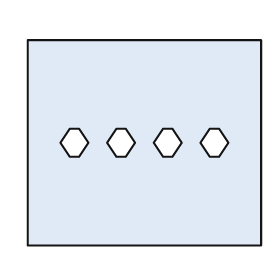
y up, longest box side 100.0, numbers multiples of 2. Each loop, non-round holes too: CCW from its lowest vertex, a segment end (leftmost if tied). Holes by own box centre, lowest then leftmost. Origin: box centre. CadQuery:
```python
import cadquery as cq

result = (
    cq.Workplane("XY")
    .moveTo(-50.0, -44.0)
    .lineTo(50.0, -44.0)
    .lineTo(50.0, 44.0)
    .lineTo(-50.0, 44.0)
    .close()
    .moveTo(-32.0, -6.0)
    .lineTo(-28.0, -6.0)
    .lineTo(-24.0, 0.0)
    .lineTo(-28.0, 6.0)
    .lineTo(-32.0, 6.0)
    .lineTo(-36.0, 0.0)
    .close()
    .moveTo(-12.0, -6.0)
    .lineTo(-8.0, -6.0)
    .lineTo(-4.0, 0.0)
    .lineTo(-8.0, 6.0)
    .lineTo(-12.0, 6.0)
    .lineTo(-16.0, 0.0)
    .close()
    .moveTo(8.0, -6.0)
    .lineTo(12.0, -6.0)
    .lineTo(16.0, 0.0)
    .lineTo(12.0, 6.0)
    .lineTo(8.0, 6.0)
    .lineTo(4.0, 0.0)
    .close()
    .moveTo(28.0, -6.0)
    .lineTo(32.0, -6.0)
    .lineTo(36.0, 0.0)
    .lineTo(32.0, 6.0)
    .lineTo(28.0, 6.0)
    .lineTo(24.0, 0.0)
    .close()
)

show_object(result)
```